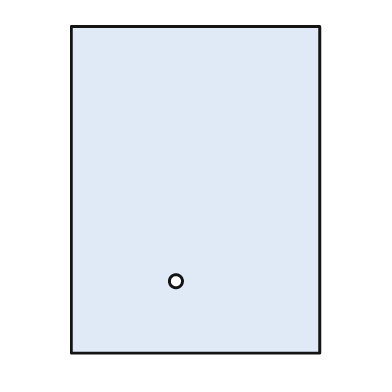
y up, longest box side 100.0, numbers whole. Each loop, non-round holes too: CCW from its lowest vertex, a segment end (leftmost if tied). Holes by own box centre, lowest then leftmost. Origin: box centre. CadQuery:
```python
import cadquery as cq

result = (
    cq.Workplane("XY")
    .moveTo(-38.0, -50.0)
    .lineTo(38.0, -50.0)
    .lineTo(38.0, 50.0)
    .lineTo(-38.0, 50.0)
    .close()
    .moveTo(-6.0, -28.0)
    .circle(2.0)
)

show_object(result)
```